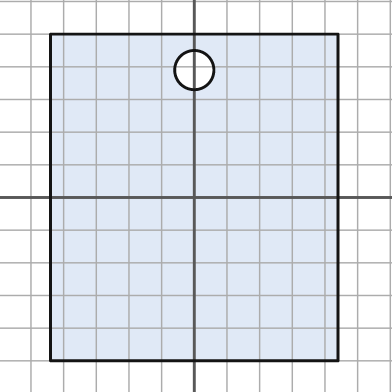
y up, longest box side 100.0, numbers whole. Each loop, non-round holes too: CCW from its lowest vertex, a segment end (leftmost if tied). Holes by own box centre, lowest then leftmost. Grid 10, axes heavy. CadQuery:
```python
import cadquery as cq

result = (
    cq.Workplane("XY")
    .moveTo(-44.0, -50.0)
    .lineTo(44.0, -50.0)
    .lineTo(44.0, 50.0)
    .lineTo(-44.0, 50.0)
    .close()
    .moveTo(0.0, 39.0)
    .circle(6.0)
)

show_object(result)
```